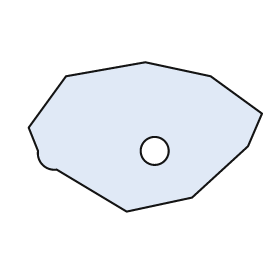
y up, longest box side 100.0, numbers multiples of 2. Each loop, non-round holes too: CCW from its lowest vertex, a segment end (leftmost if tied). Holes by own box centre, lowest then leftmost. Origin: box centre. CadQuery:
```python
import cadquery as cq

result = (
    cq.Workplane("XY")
    .moveTo(-8.0, -32.0)
    .lineTo(20.0, -26.0)
    .lineTo(44.0, -4.0)
    .lineTo(50.0, 10.0)
    .lineTo(28.0, 26.0)
    .lineTo(0.0, 32.0)
    .lineTo(-34.0, 26.0)
    .lineTo(-50.0, 4.0)
    .lineTo(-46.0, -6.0)
    .threePointArc((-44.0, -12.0), (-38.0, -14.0))
    .close()
    .moveTo(4.0, -6.0)
    .circle(6.0)
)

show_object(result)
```